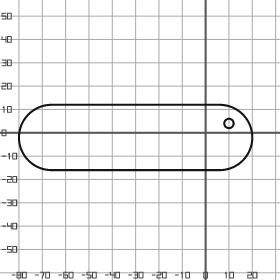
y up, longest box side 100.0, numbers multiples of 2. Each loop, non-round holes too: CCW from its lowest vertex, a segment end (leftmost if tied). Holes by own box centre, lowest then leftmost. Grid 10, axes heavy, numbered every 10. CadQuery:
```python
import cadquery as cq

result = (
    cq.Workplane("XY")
    .moveTo(-66.0, -16.0)
    .lineTo(6.0, -16.0)
    .threePointArc((20.0, -2.0), (6.0, 12.0))
    .lineTo(-66.0, 12.0)
    .threePointArc((-80.0, -2.0), (-66.0, -16.0))
    .close()
    .moveTo(10.0, 4.0)
    .circle(2.0)
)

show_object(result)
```